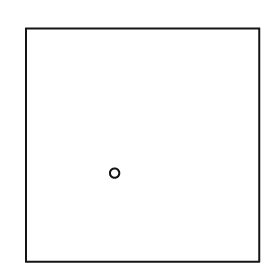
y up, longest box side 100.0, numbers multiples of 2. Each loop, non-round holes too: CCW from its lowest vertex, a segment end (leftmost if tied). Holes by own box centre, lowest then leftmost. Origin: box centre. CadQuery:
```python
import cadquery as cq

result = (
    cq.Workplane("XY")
    .moveTo(-50.0, -50.0)
    .lineTo(50.0, -50.0)
    .lineTo(50.0, 50.0)
    .lineTo(-50.0, 50.0)
    .close()
    .moveTo(-12.0, -12.0)
    .circle(2.0)
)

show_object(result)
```